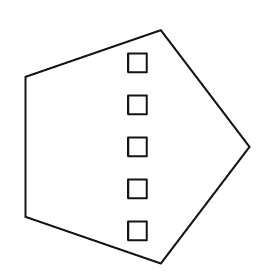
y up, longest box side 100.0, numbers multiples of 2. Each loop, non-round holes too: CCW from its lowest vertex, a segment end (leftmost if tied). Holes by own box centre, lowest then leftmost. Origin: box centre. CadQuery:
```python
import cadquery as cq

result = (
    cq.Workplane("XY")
    .moveTo(10.0, -50.0)
    .lineTo(48.0, 0.0)
    .lineTo(10.0, 50.0)
    .lineTo(-48.0, 30.0)
    .lineTo(-48.0, -30.0)
    .close()
    .moveTo(-4.0, -40.0)
    .lineTo(4.0, -40.0)
    .lineTo(4.0, -32.0)
    .lineTo(-4.0, -32.0)
    .close()
    .moveTo(-4.0, -22.0)
    .lineTo(4.0, -22.0)
    .lineTo(4.0, -14.0)
    .lineTo(-4.0, -14.0)
    .close()
    .moveTo(-4.0, -4.0)
    .lineTo(4.0, -4.0)
    .lineTo(4.0, 4.0)
    .lineTo(-4.0, 4.0)
    .close()
    .moveTo(-4.0, 14.0)
    .lineTo(4.0, 14.0)
    .lineTo(4.0, 22.0)
    .lineTo(-4.0, 22.0)
    .close()
    .moveTo(-4.0, 32.0)
    .lineTo(4.0, 32.0)
    .lineTo(4.0, 40.0)
    .lineTo(-4.0, 40.0)
    .close()
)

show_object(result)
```